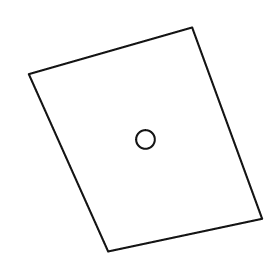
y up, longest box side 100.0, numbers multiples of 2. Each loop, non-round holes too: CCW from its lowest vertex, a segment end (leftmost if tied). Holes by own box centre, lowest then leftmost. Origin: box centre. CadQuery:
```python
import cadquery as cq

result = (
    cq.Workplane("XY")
    .moveTo(-16.0, -48.0)
    .lineTo(50.0, -34.0)
    .lineTo(20.0, 48.0)
    .lineTo(-50.0, 28.0)
    .close()
    .moveTo(0.0, 0.0)
    .circle(4.0)
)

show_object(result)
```